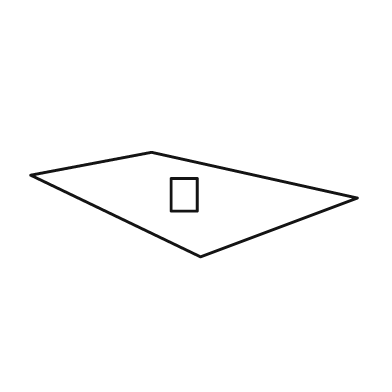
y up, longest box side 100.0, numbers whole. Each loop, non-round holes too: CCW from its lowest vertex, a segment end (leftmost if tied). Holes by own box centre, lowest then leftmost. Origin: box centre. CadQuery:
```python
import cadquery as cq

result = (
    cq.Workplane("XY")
    .moveTo(2.0, -16.0)
    .lineTo(50.0, 2.0)
    .lineTo(-13.0, 16.0)
    .lineTo(-50.0, 9.0)
    .close()
    .moveTo(-7.0, -2.0)
    .lineTo(1.0, -2.0)
    .lineTo(1.0, 8.0)
    .lineTo(-7.0, 8.0)
    .close()
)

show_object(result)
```